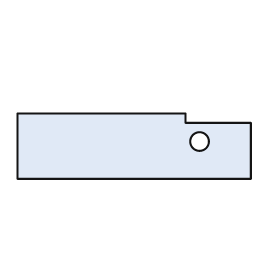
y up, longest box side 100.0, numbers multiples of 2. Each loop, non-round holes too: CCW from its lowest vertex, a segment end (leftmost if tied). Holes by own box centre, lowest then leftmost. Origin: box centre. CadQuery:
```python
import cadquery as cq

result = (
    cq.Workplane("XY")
    .moveTo(-50.0, -14.0)
    .lineTo(50.0, -14.0)
    .lineTo(50.0, 10.0)
    .lineTo(22.0, 10.0)
    .lineTo(22.0, 14.0)
    .lineTo(-50.0, 14.0)
    .close()
    .moveTo(28.0, 2.0)
    .circle(4.0)
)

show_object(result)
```